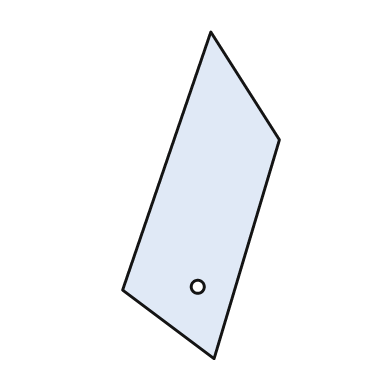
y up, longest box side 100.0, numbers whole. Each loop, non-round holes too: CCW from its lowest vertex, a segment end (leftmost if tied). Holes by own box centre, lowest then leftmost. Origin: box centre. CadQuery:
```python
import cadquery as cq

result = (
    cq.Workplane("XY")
    .moveTo(4.0, -50.0)
    .lineTo(24.0, 17.0)
    .lineTo(3.0, 50.0)
    .lineTo(-24.0, -29.0)
    .close()
    .moveTo(-1.0, -28.0)
    .circle(2.0)
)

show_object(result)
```